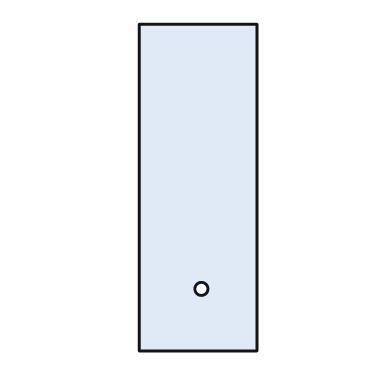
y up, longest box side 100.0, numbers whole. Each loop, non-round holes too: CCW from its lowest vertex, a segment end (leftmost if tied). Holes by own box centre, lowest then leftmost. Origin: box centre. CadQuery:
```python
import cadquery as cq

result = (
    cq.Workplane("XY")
    .moveTo(-18.0, -50.0)
    .lineTo(18.0, -50.0)
    .lineTo(18.0, 50.0)
    .lineTo(-18.0, 50.0)
    .close()
    .moveTo(1.0, -31.0)
    .circle(2.0)
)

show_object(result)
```